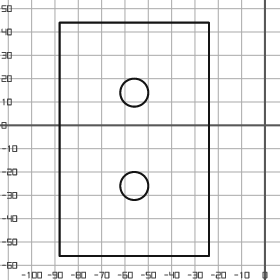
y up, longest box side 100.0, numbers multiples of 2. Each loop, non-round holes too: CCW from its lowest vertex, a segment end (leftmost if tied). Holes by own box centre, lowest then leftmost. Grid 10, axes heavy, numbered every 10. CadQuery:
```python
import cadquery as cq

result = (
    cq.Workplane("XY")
    .moveTo(-88.0, -56.0)
    .lineTo(-24.0, -56.0)
    .lineTo(-24.0, 44.0)
    .lineTo(-88.0, 44.0)
    .close()
    .moveTo(-56.0, -26.0)
    .circle(6.0)
    .moveTo(-56.0, 14.0)
    .circle(6.0)
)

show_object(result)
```